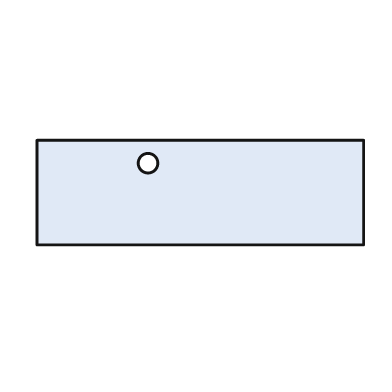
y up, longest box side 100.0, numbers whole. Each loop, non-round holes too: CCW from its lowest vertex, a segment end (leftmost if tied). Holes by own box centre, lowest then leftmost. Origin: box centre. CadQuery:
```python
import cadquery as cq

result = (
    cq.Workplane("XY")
    .moveTo(-50.0, -16.0)
    .lineTo(50.0, -16.0)
    .lineTo(50.0, 16.0)
    .lineTo(-50.0, 16.0)
    .close()
    .moveTo(-16.0, 9.0)
    .circle(3.0)
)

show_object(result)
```